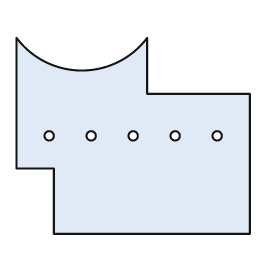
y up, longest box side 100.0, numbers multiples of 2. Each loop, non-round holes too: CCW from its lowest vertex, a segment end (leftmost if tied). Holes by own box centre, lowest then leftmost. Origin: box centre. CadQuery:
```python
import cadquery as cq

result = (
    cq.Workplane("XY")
    .moveTo(-34.0, -42.0)
    .lineTo(50.0, -42.0)
    .lineTo(50.0, 18.0)
    .lineTo(6.0, 18.0)
    .lineTo(6.0, 42.0)
    .threePointArc((-22.0, 28.0), (-50.0, 42.0))
    .lineTo(-50.0, -14.0)
    .lineTo(-34.0, -14.0)
    .close()
    .moveTo(-36.0, 0.0)
    .circle(2.0)
    .moveTo(-18.0, 0.0)
    .circle(2.0)
    .moveTo(0.0, 0.0)
    .circle(2.0)
    .moveTo(18.0, 0.0)
    .circle(2.0)
    .moveTo(36.0, 0.0)
    .circle(2.0)
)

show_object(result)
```